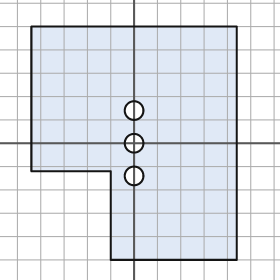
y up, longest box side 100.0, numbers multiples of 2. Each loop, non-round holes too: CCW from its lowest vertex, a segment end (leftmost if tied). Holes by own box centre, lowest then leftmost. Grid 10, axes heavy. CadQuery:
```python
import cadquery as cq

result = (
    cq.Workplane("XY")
    .moveTo(-10.0, -50.0)
    .lineTo(44.0, -50.0)
    .lineTo(44.0, 50.0)
    .lineTo(-44.0, 50.0)
    .lineTo(-44.0, -12.0)
    .lineTo(-10.0, -12.0)
    .close()
    .moveTo(0.0, -14.0)
    .circle(4.0)
    .moveTo(0.0, 0.0)
    .circle(4.0)
    .moveTo(0.0, 14.0)
    .circle(4.0)
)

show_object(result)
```